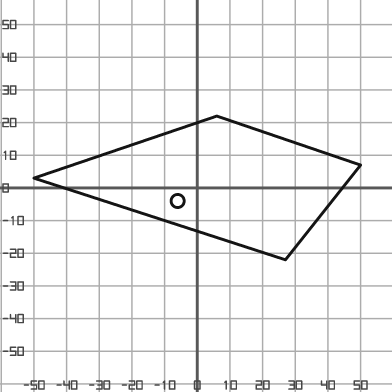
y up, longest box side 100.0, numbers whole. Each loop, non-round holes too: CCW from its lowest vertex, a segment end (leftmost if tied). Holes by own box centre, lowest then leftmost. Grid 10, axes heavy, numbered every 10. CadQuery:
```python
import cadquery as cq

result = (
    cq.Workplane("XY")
    .moveTo(27.0, -22.0)
    .lineTo(50.0, 7.0)
    .lineTo(6.0, 22.0)
    .lineTo(-50.0, 3.0)
    .close()
    .moveTo(-6.0, -4.0)
    .circle(2.0)
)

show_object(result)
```